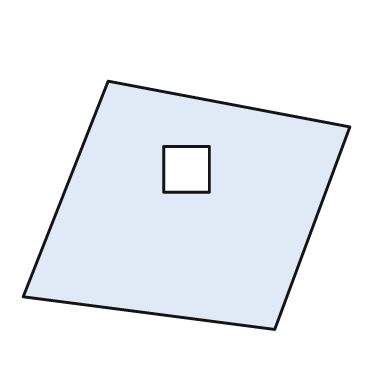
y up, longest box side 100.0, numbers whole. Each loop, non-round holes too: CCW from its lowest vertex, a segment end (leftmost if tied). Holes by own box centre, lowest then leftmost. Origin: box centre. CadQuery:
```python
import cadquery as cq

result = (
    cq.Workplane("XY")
    .moveTo(27.0, -38.0)
    .lineTo(50.0, 24.0)
    .lineTo(-24.0, 38.0)
    .lineTo(-50.0, -28.0)
    .close()
    .moveTo(-7.0, 4.0)
    .lineTo(7.0, 4.0)
    .lineTo(7.0, 18.0)
    .lineTo(-7.0, 18.0)
    .close()
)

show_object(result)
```